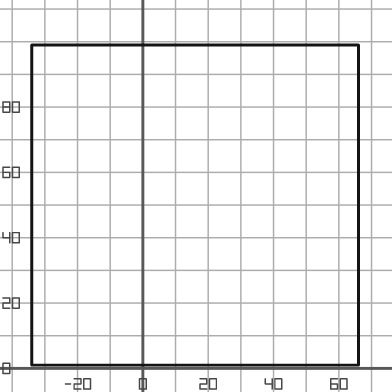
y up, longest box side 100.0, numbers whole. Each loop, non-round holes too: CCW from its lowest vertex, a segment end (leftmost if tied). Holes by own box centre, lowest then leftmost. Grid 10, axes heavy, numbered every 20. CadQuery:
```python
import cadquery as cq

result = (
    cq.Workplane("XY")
    .moveTo(-34.0, 1.0)
    .lineTo(66.0, 1.0)
    .lineTo(66.0, 99.0)
    .lineTo(-34.0, 99.0)
    .close()
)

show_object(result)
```